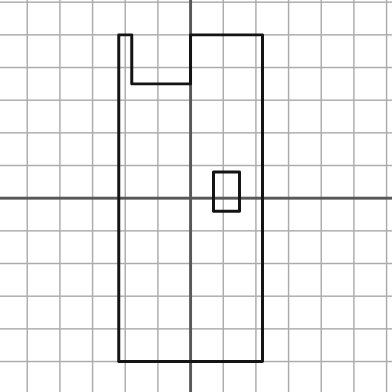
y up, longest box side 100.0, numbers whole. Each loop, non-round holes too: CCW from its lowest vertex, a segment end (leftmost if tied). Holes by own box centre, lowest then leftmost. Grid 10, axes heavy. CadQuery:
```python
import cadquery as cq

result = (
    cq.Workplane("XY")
    .moveTo(-22.0, -50.0)
    .lineTo(22.0, -50.0)
    .lineTo(22.0, 50.0)
    .lineTo(0.0, 50.0)
    .lineTo(0.0, 35.0)
    .lineTo(-18.0, 35.0)
    .lineTo(-18.0, 50.0)
    .lineTo(-22.0, 50.0)
    .close()
    .moveTo(7.0, -4.0)
    .lineTo(15.0, -4.0)
    .lineTo(15.0, 8.0)
    .lineTo(7.0, 8.0)
    .close()
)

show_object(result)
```